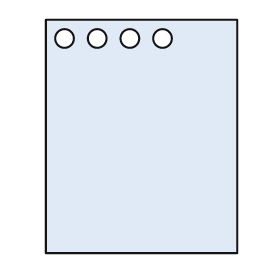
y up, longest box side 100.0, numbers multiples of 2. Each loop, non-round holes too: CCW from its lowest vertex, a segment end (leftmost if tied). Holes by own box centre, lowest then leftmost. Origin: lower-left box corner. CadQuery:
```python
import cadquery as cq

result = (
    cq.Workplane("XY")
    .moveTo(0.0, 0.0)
    .lineTo(82.0, 0.0)
    .lineTo(82.0, 100.0)
    .lineTo(0.0, 100.0)
    .close()
    .moveTo(8.0, 92.0)
    .circle(4.0)
    .moveTo(22.0, 92.0)
    .circle(4.0)
    .moveTo(36.0, 92.0)
    .circle(4.0)
    .moveTo(50.0, 92.0)
    .circle(4.0)
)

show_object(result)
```